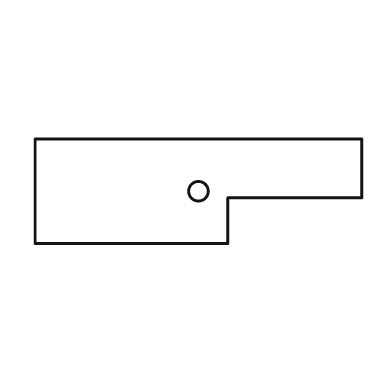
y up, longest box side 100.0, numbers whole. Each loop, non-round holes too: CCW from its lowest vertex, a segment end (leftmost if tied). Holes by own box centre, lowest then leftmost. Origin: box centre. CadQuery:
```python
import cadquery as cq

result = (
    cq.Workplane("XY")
    .moveTo(-50.0, -16.0)
    .lineTo(9.0, -16.0)
    .lineTo(9.0, -2.0)
    .lineTo(50.0, -2.0)
    .lineTo(50.0, 16.0)
    .lineTo(-50.0, 16.0)
    .close()
    .moveTo(0.0, 0.0)
    .circle(3.0)
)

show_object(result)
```